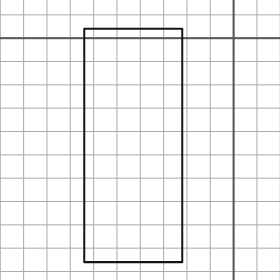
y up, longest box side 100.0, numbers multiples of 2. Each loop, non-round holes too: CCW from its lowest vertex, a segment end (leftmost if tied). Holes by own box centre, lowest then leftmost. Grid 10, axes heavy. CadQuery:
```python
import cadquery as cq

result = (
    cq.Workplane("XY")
    .moveTo(-64.0, -96.0)
    .lineTo(-22.0, -96.0)
    .lineTo(-22.0, 4.0)
    .lineTo(-64.0, 4.0)
    .close()
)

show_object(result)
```